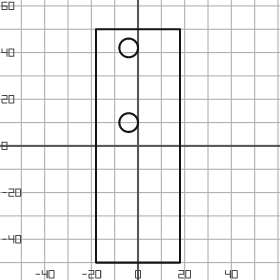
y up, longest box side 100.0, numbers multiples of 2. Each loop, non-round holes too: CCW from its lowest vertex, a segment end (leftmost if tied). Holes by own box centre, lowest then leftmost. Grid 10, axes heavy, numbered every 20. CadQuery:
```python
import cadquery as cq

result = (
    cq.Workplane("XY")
    .moveTo(-18.0, -50.0)
    .lineTo(18.0, -50.0)
    .lineTo(18.0, 50.0)
    .lineTo(-18.0, 50.0)
    .close()
    .moveTo(-4.0, 10.0)
    .circle(4.0)
    .moveTo(-4.0, 42.0)
    .circle(4.0)
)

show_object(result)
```